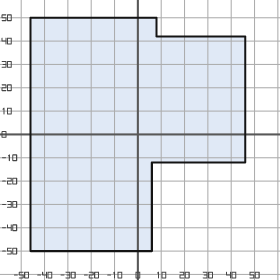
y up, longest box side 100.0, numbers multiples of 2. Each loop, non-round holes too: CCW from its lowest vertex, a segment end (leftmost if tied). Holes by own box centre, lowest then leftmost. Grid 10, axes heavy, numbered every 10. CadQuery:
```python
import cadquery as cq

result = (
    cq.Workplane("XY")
    .moveTo(-46.0, -50.0)
    .lineTo(6.0, -50.0)
    .lineTo(6.0, -12.0)
    .lineTo(46.0, -12.0)
    .lineTo(46.0, 42.0)
    .lineTo(8.0, 42.0)
    .lineTo(8.0, 50.0)
    .lineTo(-46.0, 50.0)
    .close()
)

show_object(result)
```